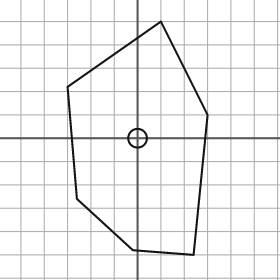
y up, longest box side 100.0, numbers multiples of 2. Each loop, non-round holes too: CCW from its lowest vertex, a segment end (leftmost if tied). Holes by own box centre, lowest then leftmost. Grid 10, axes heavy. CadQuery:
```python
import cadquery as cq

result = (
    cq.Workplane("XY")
    .moveTo(24.0, -50.0)
    .lineTo(30.0, 10.0)
    .lineTo(10.0, 50.0)
    .lineTo(-30.0, 22.0)
    .lineTo(-26.0, -26.0)
    .lineTo(-2.0, -48.0)
    .close()
    .moveTo(0.0, 0.0)
    .circle(4.0)
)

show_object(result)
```